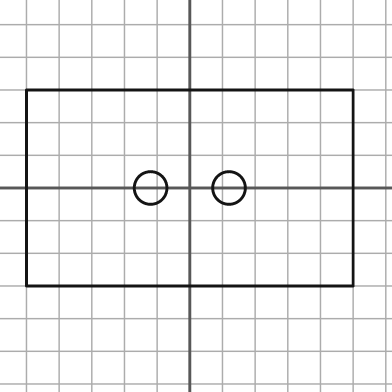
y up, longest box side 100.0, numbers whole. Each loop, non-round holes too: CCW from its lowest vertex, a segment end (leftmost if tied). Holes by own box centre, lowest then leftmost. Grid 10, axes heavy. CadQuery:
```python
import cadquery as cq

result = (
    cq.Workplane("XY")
    .moveTo(-50.0, -30.0)
    .lineTo(50.0, -30.0)
    .lineTo(50.0, 30.0)
    .lineTo(-50.0, 30.0)
    .close()
    .moveTo(-12.0, 0.0)
    .circle(5.0)
    .moveTo(12.0, 0.0)
    .circle(5.0)
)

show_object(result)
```